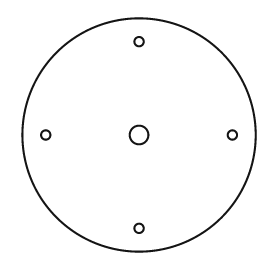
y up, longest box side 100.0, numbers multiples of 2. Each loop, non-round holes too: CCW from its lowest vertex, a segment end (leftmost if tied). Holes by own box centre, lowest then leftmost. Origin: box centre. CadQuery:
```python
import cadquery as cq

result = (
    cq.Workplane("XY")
    .moveTo(0.0, 0.0)
    .circle(50.0)
    .moveTo(0.0, -40.0)
    .circle(2.0)
    .moveTo(-40.0, 0.0)
    .circle(2.0)
    .moveTo(0.0, 0.0)
    .circle(4.0)
    .moveTo(40.0, 0.0)
    .circle(2.0)
    .moveTo(0.0, 40.0)
    .circle(2.0)
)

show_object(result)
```